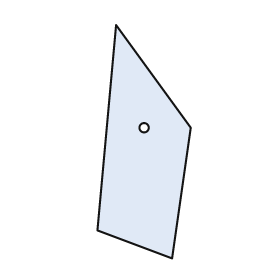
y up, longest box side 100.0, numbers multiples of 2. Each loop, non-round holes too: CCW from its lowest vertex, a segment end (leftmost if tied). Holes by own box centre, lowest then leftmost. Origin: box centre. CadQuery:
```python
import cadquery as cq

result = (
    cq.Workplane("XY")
    .moveTo(12.0, -50.0)
    .lineTo(20.0, 6.0)
    .lineTo(-12.0, 50.0)
    .lineTo(-20.0, -38.0)
    .close()
    .moveTo(0.0, 6.0)
    .circle(2.0)
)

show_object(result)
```